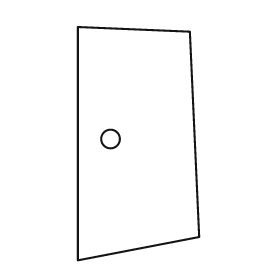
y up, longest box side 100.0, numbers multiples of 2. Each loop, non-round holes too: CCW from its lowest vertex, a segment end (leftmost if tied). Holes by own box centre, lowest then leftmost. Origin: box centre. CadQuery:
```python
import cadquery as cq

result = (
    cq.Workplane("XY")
    .moveTo(-26.0, -50.0)
    .lineTo(26.0, -40.0)
    .lineTo(22.0, 48.0)
    .lineTo(-26.0, 50.0)
    .close()
    .moveTo(-12.0, 2.0)
    .circle(4.0)
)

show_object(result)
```